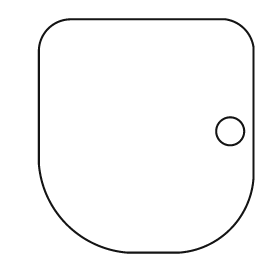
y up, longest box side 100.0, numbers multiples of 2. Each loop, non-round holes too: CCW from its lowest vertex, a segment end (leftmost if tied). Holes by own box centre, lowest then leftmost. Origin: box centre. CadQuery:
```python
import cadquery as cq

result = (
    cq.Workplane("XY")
    .moveTo(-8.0, -50.0)
    .lineTo(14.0, -50.0)
    .threePointArc((36.0, -40.0), (46.0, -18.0))
    .lineTo(46.0, 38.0)
    .threePointArc((42.0, 46.0), (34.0, 50.0))
    .lineTo(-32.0, 50.0)
    .threePointArc((-42.0, 46.0), (-46.0, 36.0))
    .lineTo(-46.0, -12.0)
    .threePointArc((-34.0, -38.0), (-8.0, -50.0))
    .close()
    .moveTo(36.0, 2.0)
    .circle(6.0)
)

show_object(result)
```